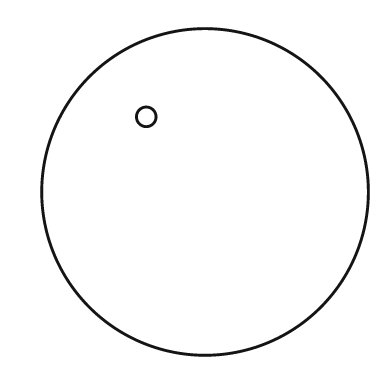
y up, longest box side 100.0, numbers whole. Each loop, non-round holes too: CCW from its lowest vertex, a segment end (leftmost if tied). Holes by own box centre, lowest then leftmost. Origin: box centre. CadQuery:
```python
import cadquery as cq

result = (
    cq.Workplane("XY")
    .moveTo(0.0, 0.0)
    .circle(50.0)
    .moveTo(-18.0, 23.0)
    .circle(3.0)
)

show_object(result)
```